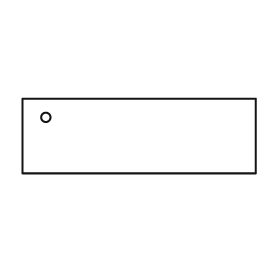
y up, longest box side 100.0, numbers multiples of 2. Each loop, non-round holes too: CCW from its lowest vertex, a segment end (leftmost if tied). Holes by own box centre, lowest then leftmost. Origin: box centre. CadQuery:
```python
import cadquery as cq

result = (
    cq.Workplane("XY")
    .moveTo(-50.0, -16.0)
    .lineTo(50.0, -16.0)
    .lineTo(50.0, 16.0)
    .lineTo(-50.0, 16.0)
    .close()
    .moveTo(-40.0, 8.0)
    .circle(2.0)
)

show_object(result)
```